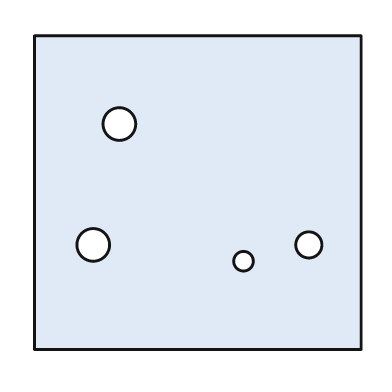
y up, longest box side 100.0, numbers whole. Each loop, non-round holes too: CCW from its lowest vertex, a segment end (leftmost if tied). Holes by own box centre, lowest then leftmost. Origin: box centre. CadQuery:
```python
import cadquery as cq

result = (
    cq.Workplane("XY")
    .moveTo(-50.0, -48.0)
    .lineTo(50.0, -48.0)
    .lineTo(50.0, 48.0)
    .lineTo(-50.0, 48.0)
    .close()
    .moveTo(14.0, -21.0)
    .circle(3.0)
    .moveTo(-32.0, -16.0)
    .circle(5.0)
    .moveTo(34.0, -16.0)
    .circle(4.0)
    .moveTo(-24.0, 21.0)
    .circle(5.0)
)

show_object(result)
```